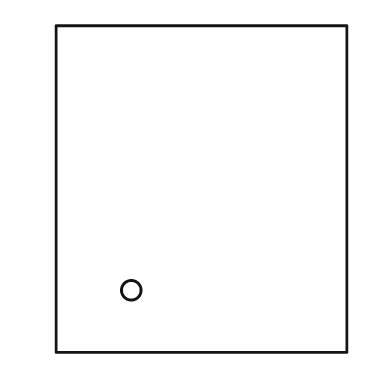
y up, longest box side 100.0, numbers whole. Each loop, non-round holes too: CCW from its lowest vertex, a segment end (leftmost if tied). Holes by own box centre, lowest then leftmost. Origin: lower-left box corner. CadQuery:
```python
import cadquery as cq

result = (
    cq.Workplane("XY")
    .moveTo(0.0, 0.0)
    .lineTo(89.0, 0.0)
    .lineTo(89.0, 100.0)
    .lineTo(0.0, 100.0)
    .close()
    .moveTo(23.0, 19.0)
    .circle(3.0)
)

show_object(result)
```